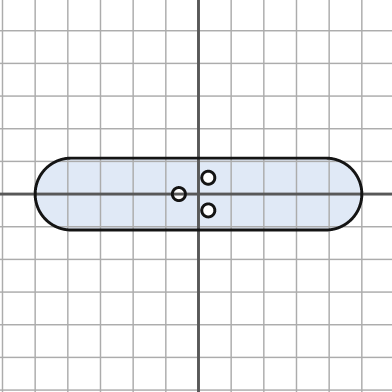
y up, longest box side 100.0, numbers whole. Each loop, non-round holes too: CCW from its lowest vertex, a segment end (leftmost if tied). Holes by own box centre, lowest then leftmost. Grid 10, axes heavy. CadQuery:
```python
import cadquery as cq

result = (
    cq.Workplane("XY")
    .moveTo(-39.0, -11.0)
    .lineTo(39.0, -11.0)
    .threePointArc((50.0, 0.0), (39.0, 11.0))
    .lineTo(-39.0, 11.0)
    .threePointArc((-50.0, 0.0), (-39.0, -11.0))
    .close()
    .moveTo(3.0, -5.0)
    .circle(2.0)
    .moveTo(-6.0, 0.0)
    .circle(2.0)
    .moveTo(3.0, 5.0)
    .circle(2.0)
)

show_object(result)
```